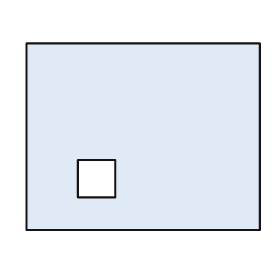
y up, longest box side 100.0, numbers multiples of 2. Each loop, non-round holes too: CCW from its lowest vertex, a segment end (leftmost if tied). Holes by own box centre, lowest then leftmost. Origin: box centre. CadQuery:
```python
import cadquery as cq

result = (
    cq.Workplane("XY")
    .moveTo(-50.0, -40.0)
    .lineTo(50.0, -40.0)
    .lineTo(50.0, 40.0)
    .lineTo(-50.0, 40.0)
    .close()
    .moveTo(-28.0, -26.0)
    .lineTo(-12.0, -26.0)
    .lineTo(-12.0, -10.0)
    .lineTo(-28.0, -10.0)
    .close()
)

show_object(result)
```